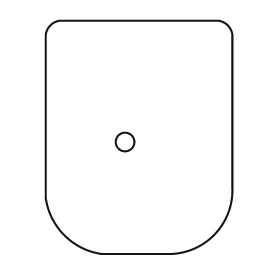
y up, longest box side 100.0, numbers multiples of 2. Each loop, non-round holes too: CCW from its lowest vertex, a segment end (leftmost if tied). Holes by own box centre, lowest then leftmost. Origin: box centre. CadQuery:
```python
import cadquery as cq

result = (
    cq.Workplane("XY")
    .moveTo(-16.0, -50.0)
    .lineTo(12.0, -50.0)
    .threePointArc((32.0, -42.0), (40.0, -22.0))
    .lineTo(40.0, 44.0)
    .threePointArc((38.0, 48.0), (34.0, 50.0))
    .lineTo(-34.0, 50.0)
    .threePointArc((-38.0, 48.0), (-40.0, 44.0))
    .lineTo(-40.0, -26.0)
    .threePointArc((-32.0, -42.0), (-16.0, -50.0))
    .close()
    .moveTo(-6.0, -2.0)
    .circle(4.0)
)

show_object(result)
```